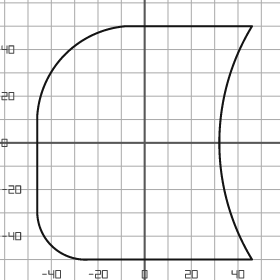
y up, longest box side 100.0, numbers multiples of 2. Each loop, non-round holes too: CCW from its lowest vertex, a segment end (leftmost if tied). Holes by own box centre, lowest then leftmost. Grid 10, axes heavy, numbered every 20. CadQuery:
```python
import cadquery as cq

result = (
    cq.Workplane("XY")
    .moveTo(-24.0, -50.0)
    .lineTo(46.0, -50.0)
    .threePointArc((32.0, 0.0), (46.0, 50.0))
    .lineTo(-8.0, 50.0)
    .threePointArc((-34.0, 38.0), (-46.0, 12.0))
    .lineTo(-46.0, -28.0)
    .threePointArc((-40.0, -44.0), (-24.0, -50.0))
    .close()
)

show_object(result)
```